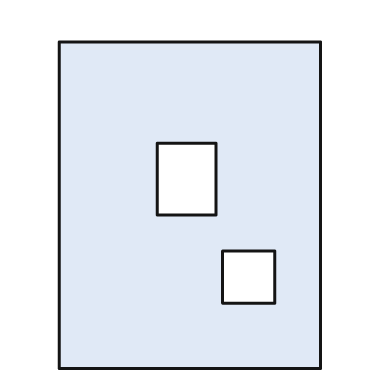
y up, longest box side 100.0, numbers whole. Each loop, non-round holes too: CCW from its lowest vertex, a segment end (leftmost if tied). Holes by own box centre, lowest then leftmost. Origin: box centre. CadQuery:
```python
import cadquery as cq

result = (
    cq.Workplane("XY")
    .moveTo(-40.0, -50.0)
    .lineTo(40.0, -50.0)
    .lineTo(40.0, 50.0)
    .lineTo(-40.0, 50.0)
    .close()
    .moveTo(10.0, -30.0)
    .lineTo(26.0, -30.0)
    .lineTo(26.0, -14.0)
    .lineTo(10.0, -14.0)
    .close()
    .moveTo(-10.0, -3.0)
    .lineTo(8.0, -3.0)
    .lineTo(8.0, 19.0)
    .lineTo(-10.0, 19.0)
    .close()
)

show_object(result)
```